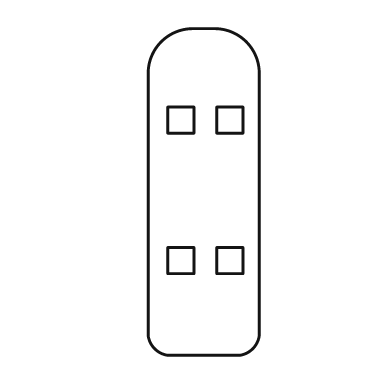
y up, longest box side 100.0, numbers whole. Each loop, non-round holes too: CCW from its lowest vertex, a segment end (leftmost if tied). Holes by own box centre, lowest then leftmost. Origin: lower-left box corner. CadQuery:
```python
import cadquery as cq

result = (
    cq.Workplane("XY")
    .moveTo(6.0, 0.0)
    .lineTo(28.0, 0.0)
    .threePointArc((32.0, 2.0), (34.0, 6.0))
    .lineTo(34.0, 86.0)
    .threePointArc((30.0, 96.0), (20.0, 100.0))
    .lineTo(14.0, 100.0)
    .threePointArc((4.0, 96.0), (0.0, 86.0))
    .lineTo(0.0, 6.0)
    .threePointArc((2.0, 2.0), (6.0, 0.0))
    .close()
    .moveTo(6.0, 25.0)
    .lineTo(14.0, 25.0)
    .lineTo(14.0, 33.0)
    .lineTo(6.0, 33.0)
    .close()
    .moveTo(21.0, 25.0)
    .lineTo(29.0, 25.0)
    .lineTo(29.0, 33.0)
    .lineTo(21.0, 33.0)
    .close()
    .moveTo(6.0, 68.0)
    .lineTo(14.0, 68.0)
    .lineTo(14.0, 76.0)
    .lineTo(6.0, 76.0)
    .close()
    .moveTo(21.0, 68.0)
    .lineTo(29.0, 68.0)
    .lineTo(29.0, 76.0)
    .lineTo(21.0, 76.0)
    .close()
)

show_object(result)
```